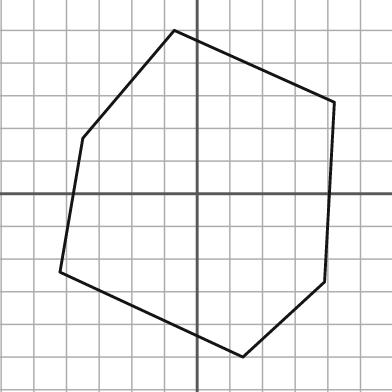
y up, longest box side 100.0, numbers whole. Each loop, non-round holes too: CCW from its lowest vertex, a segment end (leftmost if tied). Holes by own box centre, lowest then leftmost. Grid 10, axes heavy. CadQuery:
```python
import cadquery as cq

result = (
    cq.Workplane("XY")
    .moveTo(14.0, -50.0)
    .lineTo(39.0, -27.0)
    .lineTo(42.0, 28.0)
    .lineTo(-7.0, 50.0)
    .lineTo(-35.0, 17.0)
    .lineTo(-42.0, -24.0)
    .close()
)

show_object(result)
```